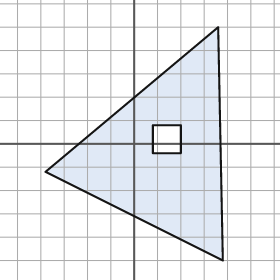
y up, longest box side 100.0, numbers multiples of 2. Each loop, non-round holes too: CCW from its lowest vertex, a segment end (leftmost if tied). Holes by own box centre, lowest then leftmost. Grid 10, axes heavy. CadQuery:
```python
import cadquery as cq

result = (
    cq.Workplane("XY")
    .moveTo(38.0, -50.0)
    .lineTo(36.0, 50.0)
    .lineTo(-38.0, -12.0)
    .close()
    .moveTo(8.0, -4.0)
    .lineTo(20.0, -4.0)
    .lineTo(20.0, 8.0)
    .lineTo(8.0, 8.0)
    .close()
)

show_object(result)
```